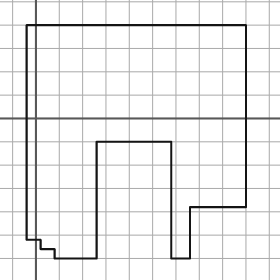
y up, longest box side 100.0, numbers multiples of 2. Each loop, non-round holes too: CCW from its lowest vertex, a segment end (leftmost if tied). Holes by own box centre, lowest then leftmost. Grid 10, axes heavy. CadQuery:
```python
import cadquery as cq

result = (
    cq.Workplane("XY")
    .moveTo(8.0, -60.0)
    .lineTo(26.0, -60.0)
    .lineTo(26.0, -10.0)
    .lineTo(58.0, -10.0)
    .lineTo(58.0, -60.0)
    .lineTo(66.0, -60.0)
    .lineTo(66.0, -38.0)
    .lineTo(90.0, -38.0)
    .lineTo(90.0, 40.0)
    .lineTo(-4.0, 40.0)
    .lineTo(-4.0, -52.0)
    .lineTo(2.0, -52.0)
    .lineTo(2.0, -56.0)
    .lineTo(8.0, -56.0)
    .close()
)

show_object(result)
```